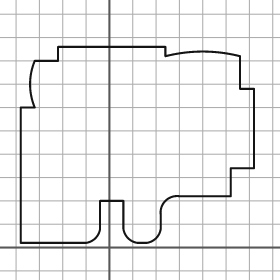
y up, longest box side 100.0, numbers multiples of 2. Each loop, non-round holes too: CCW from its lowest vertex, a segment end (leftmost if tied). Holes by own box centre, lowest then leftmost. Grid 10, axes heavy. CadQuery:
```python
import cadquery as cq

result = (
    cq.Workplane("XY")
    .moveTo(-38.0, 2.0)
    .lineTo(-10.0, 2.0)
    .threePointArc((-6.0, 4.0), (-4.0, 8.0))
    .lineTo(-4.0, 20.0)
    .lineTo(6.0, 20.0)
    .lineTo(6.0, 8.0)
    .threePointArc((8.0, 4.0), (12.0, 2.0))
    .lineTo(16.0, 2.0)
    .threePointArc((20.0, 4.0), (22.0, 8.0))
    .lineTo(22.0, 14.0)
    .threePointArc((24.0, 20.0), (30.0, 22.0))
    .lineTo(52.0, 22.0)
    .lineTo(52.0, 34.0)
    .lineTo(62.0, 34.0)
    .lineTo(62.0, 68.0)
    .lineTo(56.0, 68.0)
    .lineTo(56.0, 82.0)
    .threePointArc((40.0, 84.0), (24.0, 82.0))
    .lineTo(24.0, 86.0)
    .lineTo(-22.0, 86.0)
    .lineTo(-22.0, 80.0)
    .lineTo(-32.0, 80.0)
    .threePointArc((-34.0, 70.0), (-32.0, 60.0))
    .lineTo(-38.0, 60.0)
    .close()
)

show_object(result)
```